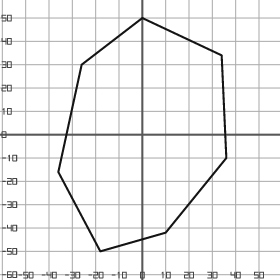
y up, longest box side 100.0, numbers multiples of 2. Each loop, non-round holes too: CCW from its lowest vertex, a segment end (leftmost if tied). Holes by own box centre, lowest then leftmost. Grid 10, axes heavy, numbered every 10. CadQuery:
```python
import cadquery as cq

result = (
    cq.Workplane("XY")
    .moveTo(-18.0, -50.0)
    .lineTo(10.0, -42.0)
    .lineTo(36.0, -10.0)
    .lineTo(34.0, 34.0)
    .lineTo(0.0, 50.0)
    .lineTo(-26.0, 30.0)
    .lineTo(-36.0, -16.0)
    .close()
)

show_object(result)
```